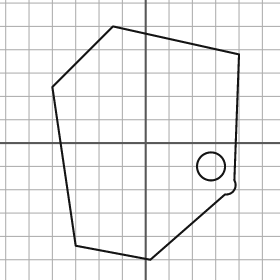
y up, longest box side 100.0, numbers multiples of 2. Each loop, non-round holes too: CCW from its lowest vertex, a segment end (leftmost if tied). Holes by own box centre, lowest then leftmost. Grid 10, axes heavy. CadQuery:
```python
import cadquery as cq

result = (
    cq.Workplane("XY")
    .moveTo(2.0, -50.0)
    .lineTo(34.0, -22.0)
    .threePointArc((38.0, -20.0), (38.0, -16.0))
    .lineTo(40.0, 38.0)
    .lineTo(-14.0, 50.0)
    .lineTo(-40.0, 24.0)
    .lineTo(-30.0, -44.0)
    .close()
    .moveTo(28.0, -10.0)
    .circle(6.0)
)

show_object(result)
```